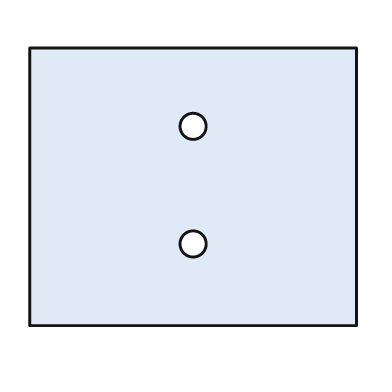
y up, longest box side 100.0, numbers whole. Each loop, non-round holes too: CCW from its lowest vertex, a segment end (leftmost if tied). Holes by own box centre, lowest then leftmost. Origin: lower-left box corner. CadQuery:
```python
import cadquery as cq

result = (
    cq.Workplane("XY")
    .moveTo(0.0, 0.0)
    .lineTo(100.0, 0.0)
    .lineTo(100.0, 85.0)
    .lineTo(0.0, 85.0)
    .close()
    .moveTo(50.0, 25.0)
    .circle(4.0)
    .moveTo(50.0, 61.0)
    .circle(4.0)
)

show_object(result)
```